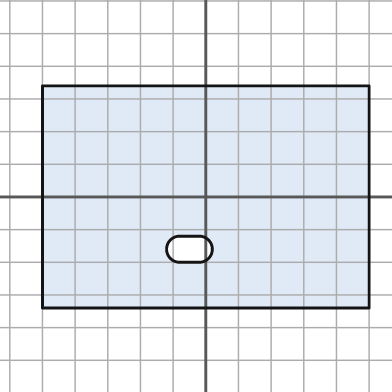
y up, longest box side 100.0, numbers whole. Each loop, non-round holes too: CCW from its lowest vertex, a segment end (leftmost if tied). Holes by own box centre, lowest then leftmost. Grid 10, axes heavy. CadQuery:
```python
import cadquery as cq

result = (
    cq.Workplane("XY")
    .moveTo(-50.0, -34.0)
    .lineTo(50.0, -34.0)
    .lineTo(50.0, 34.0)
    .lineTo(-50.0, 34.0)
    .close()
    .moveTo(-8.0, -20.0)
    .lineTo(-2.0, -20.0)
    .threePointArc((2.0, -16.0), (-2.0, -12.0))
    .lineTo(-8.0, -12.0)
    .threePointArc((-12.0, -16.0), (-8.0, -20.0))
    .close()
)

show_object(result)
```